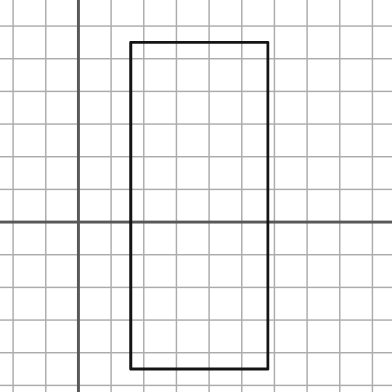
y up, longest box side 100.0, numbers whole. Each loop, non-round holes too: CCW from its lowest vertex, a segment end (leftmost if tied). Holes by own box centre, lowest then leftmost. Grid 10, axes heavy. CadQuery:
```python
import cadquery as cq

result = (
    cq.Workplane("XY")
    .moveTo(16.0, -45.0)
    .lineTo(58.0, -45.0)
    .lineTo(58.0, 55.0)
    .lineTo(16.0, 55.0)
    .close()
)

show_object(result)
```